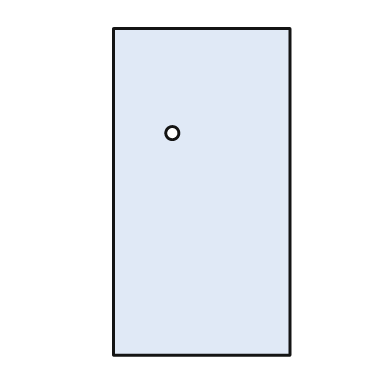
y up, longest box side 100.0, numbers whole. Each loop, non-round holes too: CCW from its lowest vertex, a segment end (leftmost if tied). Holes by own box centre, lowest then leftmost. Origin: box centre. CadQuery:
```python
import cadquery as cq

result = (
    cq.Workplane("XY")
    .moveTo(-27.0, -50.0)
    .lineTo(27.0, -50.0)
    .lineTo(27.0, 50.0)
    .lineTo(-27.0, 50.0)
    .close()
    .moveTo(-9.0, 18.0)
    .circle(2.0)
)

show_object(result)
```